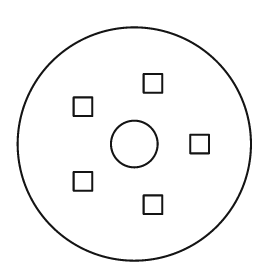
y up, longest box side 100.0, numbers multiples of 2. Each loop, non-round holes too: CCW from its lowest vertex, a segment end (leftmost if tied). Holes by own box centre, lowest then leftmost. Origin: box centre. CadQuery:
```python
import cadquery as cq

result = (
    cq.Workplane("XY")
    .moveTo(0.0, 0.0)
    .circle(50.0)
    .moveTo(4.0, -30.0)
    .lineTo(12.0, -30.0)
    .lineTo(12.0, -22.0)
    .lineTo(4.0, -22.0)
    .close()
    .moveTo(-26.0, -20.0)
    .lineTo(-18.0, -20.0)
    .lineTo(-18.0, -12.0)
    .lineTo(-26.0, -12.0)
    .close()
    .moveTo(0.0, 0.0)
    .circle(10.0)
    .moveTo(24.0, -4.0)
    .lineTo(32.0, -4.0)
    .lineTo(32.0, 4.0)
    .lineTo(24.0, 4.0)
    .close()
    .moveTo(-26.0, 12.0)
    .lineTo(-18.0, 12.0)
    .lineTo(-18.0, 20.0)
    .lineTo(-26.0, 20.0)
    .close()
    .moveTo(4.0, 22.0)
    .lineTo(12.0, 22.0)
    .lineTo(12.0, 30.0)
    .lineTo(4.0, 30.0)
    .close()
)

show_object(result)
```